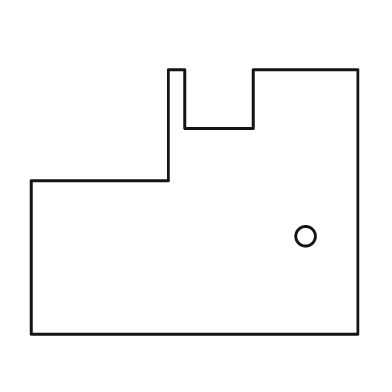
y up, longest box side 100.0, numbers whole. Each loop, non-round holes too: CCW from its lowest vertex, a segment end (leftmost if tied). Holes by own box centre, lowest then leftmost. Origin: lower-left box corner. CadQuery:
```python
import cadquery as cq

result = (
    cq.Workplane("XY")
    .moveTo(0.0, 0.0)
    .lineTo(100.0, 0.0)
    .lineTo(100.0, 81.0)
    .lineTo(68.0, 81.0)
    .lineTo(68.0, 63.0)
    .lineTo(47.0, 63.0)
    .lineTo(47.0, 81.0)
    .lineTo(42.0, 81.0)
    .lineTo(42.0, 47.0)
    .lineTo(0.0, 47.0)
    .close()
    .moveTo(84.0, 30.0)
    .circle(3.0)
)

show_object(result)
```